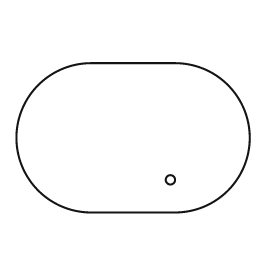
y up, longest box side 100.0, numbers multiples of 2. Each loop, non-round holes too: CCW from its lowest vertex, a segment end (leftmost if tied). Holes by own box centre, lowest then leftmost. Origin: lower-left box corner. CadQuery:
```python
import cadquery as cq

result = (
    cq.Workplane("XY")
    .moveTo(32.0, 0.0)
    .lineTo(68.0, 0.0)
    .threePointArc((100.0, 32.0), (68.0, 64.0))
    .lineTo(32.0, 64.0)
    .threePointArc((0.0, 32.0), (32.0, 0.0))
    .close()
    .moveTo(66.0, 14.0)
    .circle(2.0)
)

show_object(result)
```